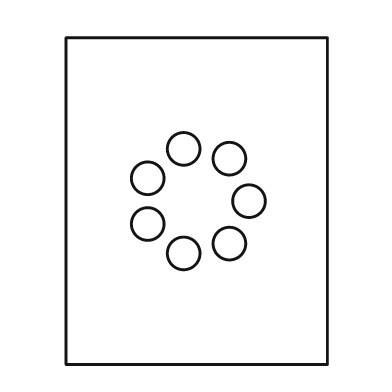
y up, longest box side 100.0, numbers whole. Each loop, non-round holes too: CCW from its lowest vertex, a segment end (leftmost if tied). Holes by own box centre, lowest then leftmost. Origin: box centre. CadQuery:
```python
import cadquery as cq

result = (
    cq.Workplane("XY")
    .moveTo(-40.0, -50.0)
    .lineTo(40.0, -50.0)
    .lineTo(40.0, 50.0)
    .lineTo(-40.0, 50.0)
    .close()
    .moveTo(-4.0, -16.0)
    .circle(5.0)
    .moveTo(10.0, -13.0)
    .circle(5.0)
    .moveTo(-15.0, -7.0)
    .circle(5.0)
    .moveTo(16.0, 0.0)
    .circle(5.0)
    .moveTo(-15.0, 7.0)
    .circle(5.0)
    .moveTo(10.0, 13.0)
    .circle(5.0)
    .moveTo(-4.0, 16.0)
    .circle(5.0)
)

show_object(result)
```